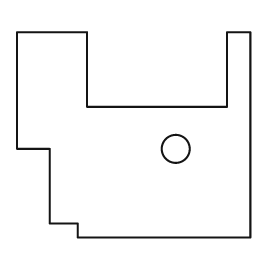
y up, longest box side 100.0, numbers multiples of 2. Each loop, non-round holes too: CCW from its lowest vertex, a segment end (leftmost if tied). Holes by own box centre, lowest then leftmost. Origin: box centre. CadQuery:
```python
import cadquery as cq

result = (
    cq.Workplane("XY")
    .moveTo(-24.0, -44.0)
    .lineTo(50.0, -44.0)
    .lineTo(50.0, 44.0)
    .lineTo(40.0, 44.0)
    .lineTo(40.0, 12.0)
    .lineTo(-20.0, 12.0)
    .lineTo(-20.0, 44.0)
    .lineTo(-50.0, 44.0)
    .lineTo(-50.0, -6.0)
    .lineTo(-36.0, -6.0)
    .lineTo(-36.0, -38.0)
    .lineTo(-24.0, -38.0)
    .close()
    .moveTo(18.0, -6.0)
    .circle(6.0)
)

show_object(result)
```